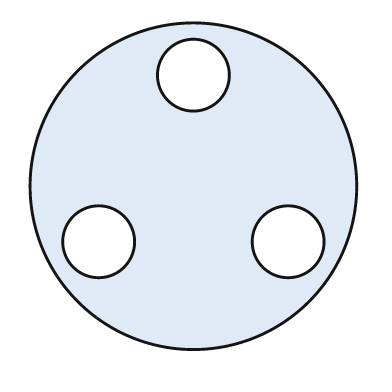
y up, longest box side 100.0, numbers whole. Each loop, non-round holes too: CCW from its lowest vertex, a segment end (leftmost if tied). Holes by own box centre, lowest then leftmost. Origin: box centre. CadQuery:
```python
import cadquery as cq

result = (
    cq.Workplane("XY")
    .moveTo(0.0, 0.0)
    .circle(50.0)
    .moveTo(-29.0, -17.0)
    .circle(11.0)
    .moveTo(29.0, -17.0)
    .circle(11.0)
    .moveTo(0.0, 34.0)
    .circle(11.0)
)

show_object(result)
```